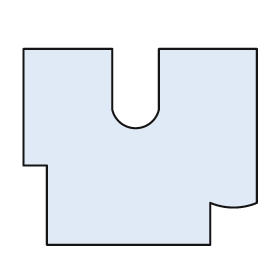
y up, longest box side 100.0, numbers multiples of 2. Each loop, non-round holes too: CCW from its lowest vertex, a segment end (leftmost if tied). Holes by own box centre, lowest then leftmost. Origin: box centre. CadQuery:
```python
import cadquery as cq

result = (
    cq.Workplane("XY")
    .moveTo(-40.0, -42.0)
    .lineTo(30.0, -42.0)
    .lineTo(30.0, -24.0)
    .threePointArc((40.0, -26.0), (50.0, -24.0))
    .lineTo(50.0, 42.0)
    .lineTo(8.0, 42.0)
    .lineTo(8.0, 16.0)
    .threePointArc((-2.0, 8.0), (-12.0, 16.0))
    .lineTo(-12.0, 42.0)
    .lineTo(-50.0, 42.0)
    .lineTo(-50.0, -8.0)
    .lineTo(-40.0, -8.0)
    .close()
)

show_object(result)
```